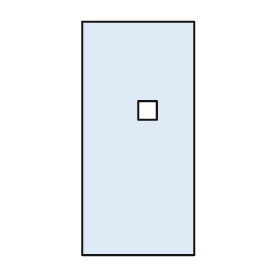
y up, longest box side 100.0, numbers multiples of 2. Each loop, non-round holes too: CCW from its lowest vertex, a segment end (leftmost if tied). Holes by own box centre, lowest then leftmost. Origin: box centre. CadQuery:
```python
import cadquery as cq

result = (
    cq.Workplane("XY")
    .moveTo(-24.0, -50.0)
    .lineTo(24.0, -50.0)
    .lineTo(24.0, 50.0)
    .lineTo(-24.0, 50.0)
    .close()
    .moveTo(0.0, 8.0)
    .lineTo(8.0, 8.0)
    .lineTo(8.0, 16.0)
    .lineTo(0.0, 16.0)
    .close()
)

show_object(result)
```